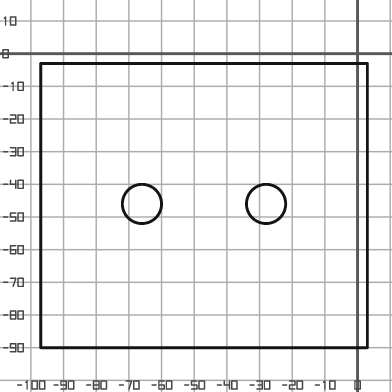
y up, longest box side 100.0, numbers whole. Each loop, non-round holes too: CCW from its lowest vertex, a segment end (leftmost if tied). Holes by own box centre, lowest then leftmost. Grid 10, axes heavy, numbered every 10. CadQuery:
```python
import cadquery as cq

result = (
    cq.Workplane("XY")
    .moveTo(-97.0, -90.0)
    .lineTo(3.0, -90.0)
    .lineTo(3.0, -3.0)
    .lineTo(-97.0, -3.0)
    .close()
    .moveTo(-66.0, -46.0)
    .circle(6.0)
    .moveTo(-28.0, -46.0)
    .circle(6.0)
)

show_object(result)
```